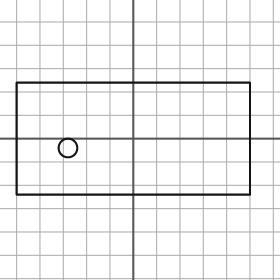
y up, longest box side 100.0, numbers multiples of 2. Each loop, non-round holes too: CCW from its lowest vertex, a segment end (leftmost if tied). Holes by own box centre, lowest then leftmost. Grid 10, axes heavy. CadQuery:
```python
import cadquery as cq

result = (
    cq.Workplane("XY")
    .moveTo(-50.0, -24.0)
    .lineTo(50.0, -24.0)
    .lineTo(50.0, 24.0)
    .lineTo(-50.0, 24.0)
    .close()
    .moveTo(-28.0, -4.0)
    .circle(4.0)
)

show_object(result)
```